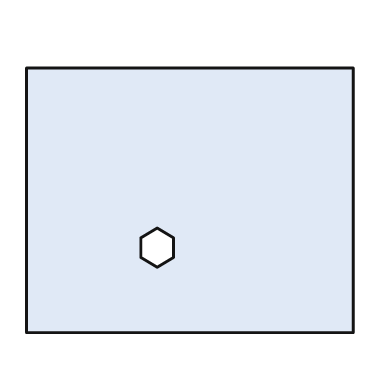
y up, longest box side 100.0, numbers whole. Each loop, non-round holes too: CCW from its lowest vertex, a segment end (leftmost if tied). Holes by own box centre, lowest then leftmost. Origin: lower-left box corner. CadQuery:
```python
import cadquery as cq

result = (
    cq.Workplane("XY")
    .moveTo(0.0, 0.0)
    .lineTo(100.0, 0.0)
    .lineTo(100.0, 81.0)
    .lineTo(0.0, 81.0)
    .close()
    .moveTo(40.0, 20.0)
    .lineTo(45.0, 23.0)
    .lineTo(45.0, 29.0)
    .lineTo(40.0, 32.0)
    .lineTo(35.0, 29.0)
    .lineTo(35.0, 23.0)
    .close()
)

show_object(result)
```